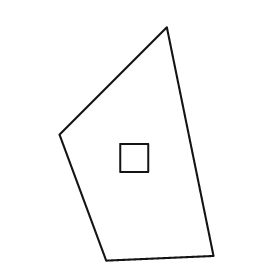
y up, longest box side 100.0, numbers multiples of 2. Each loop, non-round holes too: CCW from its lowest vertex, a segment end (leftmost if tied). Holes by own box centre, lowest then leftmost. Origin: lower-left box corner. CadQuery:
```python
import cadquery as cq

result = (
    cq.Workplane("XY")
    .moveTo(20.0, 0.0)
    .lineTo(66.0, 2.0)
    .lineTo(46.0, 100.0)
    .lineTo(0.0, 54.0)
    .close()
    .moveTo(26.0, 38.0)
    .lineTo(38.0, 38.0)
    .lineTo(38.0, 50.0)
    .lineTo(26.0, 50.0)
    .close()
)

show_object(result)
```